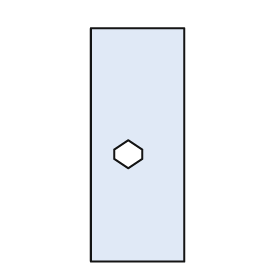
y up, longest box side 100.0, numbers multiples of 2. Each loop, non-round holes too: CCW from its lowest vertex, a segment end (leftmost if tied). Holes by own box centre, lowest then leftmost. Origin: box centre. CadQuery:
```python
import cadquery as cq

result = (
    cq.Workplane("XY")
    .moveTo(-20.0, -50.0)
    .lineTo(20.0, -50.0)
    .lineTo(20.0, 50.0)
    .lineTo(-20.0, 50.0)
    .close()
    .moveTo(-4.0, -10.0)
    .lineTo(2.0, -6.0)
    .lineTo(2.0, -2.0)
    .lineTo(-4.0, 2.0)
    .lineTo(-10.0, -2.0)
    .lineTo(-10.0, -6.0)
    .close()
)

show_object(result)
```